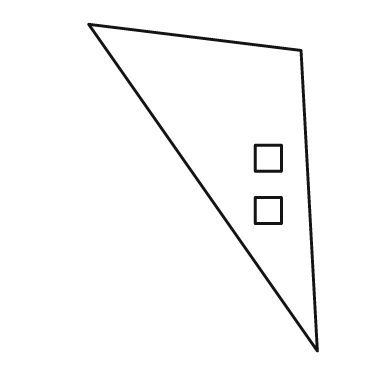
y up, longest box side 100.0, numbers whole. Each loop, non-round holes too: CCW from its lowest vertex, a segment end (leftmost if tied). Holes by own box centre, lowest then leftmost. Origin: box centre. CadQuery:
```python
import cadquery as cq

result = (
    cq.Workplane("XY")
    .moveTo(35.0, -50.0)
    .lineTo(30.0, 42.0)
    .lineTo(-35.0, 50.0)
    .close()
    .moveTo(16.0, -11.0)
    .lineTo(24.0, -11.0)
    .lineTo(24.0, -3.0)
    .lineTo(16.0, -3.0)
    .close()
    .moveTo(16.0, 5.0)
    .lineTo(24.0, 5.0)
    .lineTo(24.0, 13.0)
    .lineTo(16.0, 13.0)
    .close()
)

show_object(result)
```